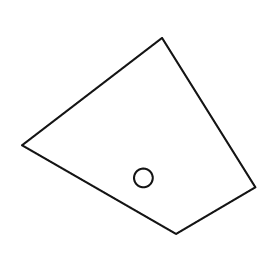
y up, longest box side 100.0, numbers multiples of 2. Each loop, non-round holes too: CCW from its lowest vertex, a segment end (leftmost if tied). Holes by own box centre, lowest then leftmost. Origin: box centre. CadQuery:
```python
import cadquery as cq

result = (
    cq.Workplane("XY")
    .moveTo(16.0, -42.0)
    .lineTo(50.0, -22.0)
    .lineTo(10.0, 42.0)
    .lineTo(-50.0, -4.0)
    .close()
    .moveTo(2.0, -18.0)
    .circle(4.0)
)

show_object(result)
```